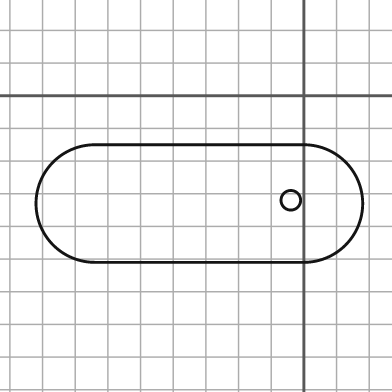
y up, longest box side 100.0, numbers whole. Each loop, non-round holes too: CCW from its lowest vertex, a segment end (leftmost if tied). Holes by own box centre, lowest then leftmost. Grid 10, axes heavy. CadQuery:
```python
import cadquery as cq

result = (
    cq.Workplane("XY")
    .moveTo(-64.0, -51.0)
    .lineTo(0.0, -51.0)
    .threePointArc((18.0, -33.0), (0.0, -15.0))
    .lineTo(-64.0, -15.0)
    .threePointArc((-82.0, -33.0), (-64.0, -51.0))
    .close()
    .moveTo(-4.0, -32.0)
    .circle(3.0)
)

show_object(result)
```